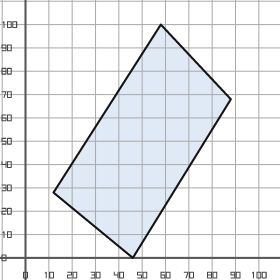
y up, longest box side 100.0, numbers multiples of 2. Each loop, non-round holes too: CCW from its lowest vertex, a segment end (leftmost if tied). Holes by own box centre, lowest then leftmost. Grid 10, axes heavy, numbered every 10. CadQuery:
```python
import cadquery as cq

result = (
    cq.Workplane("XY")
    .moveTo(46.0, 0.0)
    .lineTo(88.0, 68.0)
    .lineTo(58.0, 100.0)
    .lineTo(12.0, 28.0)
    .close()
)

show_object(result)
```